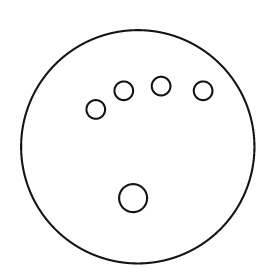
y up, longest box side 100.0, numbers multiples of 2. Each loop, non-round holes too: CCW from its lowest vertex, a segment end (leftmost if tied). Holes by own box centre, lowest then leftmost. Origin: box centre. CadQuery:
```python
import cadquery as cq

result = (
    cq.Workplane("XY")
    .moveTo(0.0, 0.0)
    .circle(50.0)
    .moveTo(-2.0, -22.0)
    .circle(6.0)
    .moveTo(-18.0, 16.0)
    .circle(4.0)
    .moveTo(-6.0, 24.0)
    .circle(4.0)
    .moveTo(28.0, 24.0)
    .circle(4.0)
    .moveTo(10.0, 26.0)
    .circle(4.0)
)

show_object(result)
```